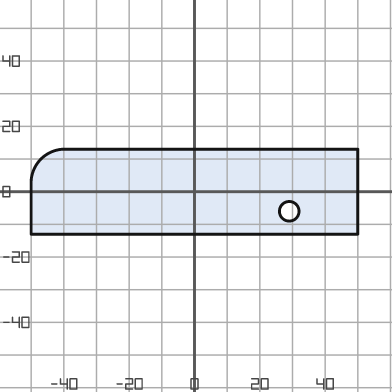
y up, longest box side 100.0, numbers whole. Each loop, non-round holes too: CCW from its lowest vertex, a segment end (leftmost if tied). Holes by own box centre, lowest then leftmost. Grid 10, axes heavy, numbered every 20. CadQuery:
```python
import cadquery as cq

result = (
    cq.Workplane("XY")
    .moveTo(-50.0, -13.0)
    .lineTo(50.0, -13.0)
    .lineTo(50.0, 13.0)
    .lineTo(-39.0, 13.0)
    .threePointArc((-47.0, 10.0), (-50.0, 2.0))
    .close()
    .moveTo(29.0, -6.0)
    .circle(3.0)
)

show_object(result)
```